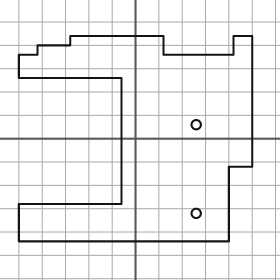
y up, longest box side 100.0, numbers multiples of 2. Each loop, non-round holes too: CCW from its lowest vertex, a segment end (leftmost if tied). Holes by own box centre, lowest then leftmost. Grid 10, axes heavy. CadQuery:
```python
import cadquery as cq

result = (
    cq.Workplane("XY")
    .moveTo(-50.0, -44.0)
    .lineTo(40.0, -44.0)
    .lineTo(40.0, -12.0)
    .lineTo(50.0, -12.0)
    .lineTo(50.0, 44.0)
    .lineTo(42.0, 44.0)
    .lineTo(42.0, 36.0)
    .lineTo(12.0, 36.0)
    .lineTo(12.0, 44.0)
    .lineTo(-28.0, 44.0)
    .lineTo(-28.0, 40.0)
    .lineTo(-42.0, 40.0)
    .lineTo(-42.0, 36.0)
    .lineTo(-50.0, 36.0)
    .lineTo(-50.0, 26.0)
    .lineTo(-6.0, 26.0)
    .lineTo(-6.0, -28.0)
    .lineTo(-50.0, -28.0)
    .close()
    .moveTo(26.0, -32.0)
    .circle(2.0)
    .moveTo(26.0, 6.0)
    .circle(2.0)
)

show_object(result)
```